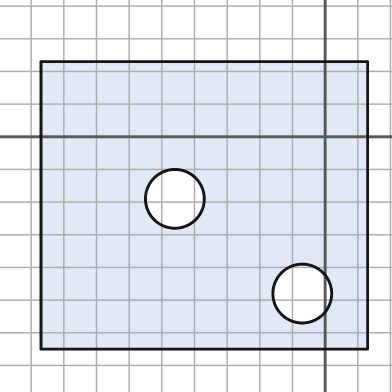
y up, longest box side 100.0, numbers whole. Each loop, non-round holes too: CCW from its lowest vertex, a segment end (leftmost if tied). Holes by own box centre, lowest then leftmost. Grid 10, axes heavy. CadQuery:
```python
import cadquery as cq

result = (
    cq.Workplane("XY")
    .moveTo(-87.0, -65.0)
    .lineTo(13.0, -65.0)
    .lineTo(13.0, 23.0)
    .lineTo(-87.0, 23.0)
    .close()
    .moveTo(-7.0, -48.0)
    .circle(9.0)
    .moveTo(-46.0, -19.0)
    .circle(9.0)
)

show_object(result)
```